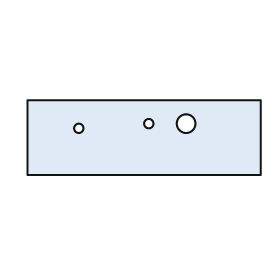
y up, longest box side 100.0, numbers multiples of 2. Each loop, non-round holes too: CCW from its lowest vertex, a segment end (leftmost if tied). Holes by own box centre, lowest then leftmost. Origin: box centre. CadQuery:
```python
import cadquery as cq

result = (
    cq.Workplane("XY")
    .moveTo(-50.0, -16.0)
    .lineTo(50.0, -16.0)
    .lineTo(50.0, 16.0)
    .lineTo(-50.0, 16.0)
    .close()
    .moveTo(-28.0, 4.0)
    .circle(2.0)
    .moveTo(2.0, 6.0)
    .circle(2.0)
    .moveTo(18.0, 6.0)
    .circle(4.0)
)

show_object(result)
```